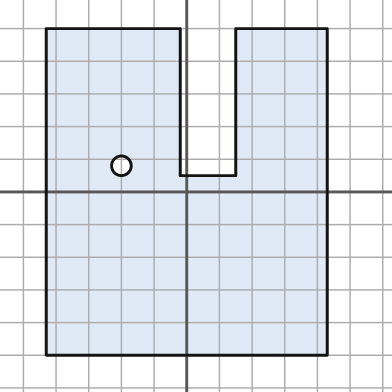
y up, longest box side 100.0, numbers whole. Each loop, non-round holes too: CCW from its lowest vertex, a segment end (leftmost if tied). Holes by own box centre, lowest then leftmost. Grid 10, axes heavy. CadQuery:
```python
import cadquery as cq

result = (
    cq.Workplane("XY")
    .moveTo(-43.0, -50.0)
    .lineTo(43.0, -50.0)
    .lineTo(43.0, 50.0)
    .lineTo(15.0, 50.0)
    .lineTo(15.0, 5.0)
    .lineTo(-2.0, 5.0)
    .lineTo(-2.0, 50.0)
    .lineTo(-43.0, 50.0)
    .close()
    .moveTo(-20.0, 8.0)
    .circle(3.0)
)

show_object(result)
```